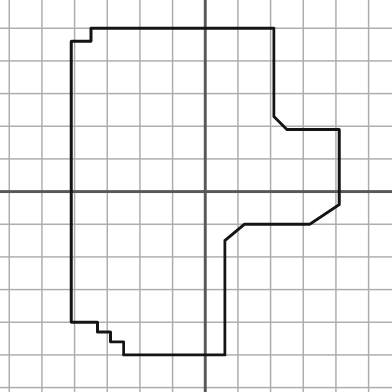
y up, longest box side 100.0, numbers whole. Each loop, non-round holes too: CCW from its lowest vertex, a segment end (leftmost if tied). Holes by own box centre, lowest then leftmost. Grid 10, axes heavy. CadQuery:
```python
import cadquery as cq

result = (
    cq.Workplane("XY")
    .moveTo(-25.0, -50.0)
    .lineTo(6.0, -50.0)
    .lineTo(6.0, -15.0)
    .lineTo(12.0, -10.0)
    .lineTo(32.0, -10.0)
    .lineTo(41.0, -4.0)
    .lineTo(41.0, 19.0)
    .lineTo(25.0, 19.0)
    .lineTo(21.0, 23.0)
    .lineTo(21.0, 50.0)
    .lineTo(-35.0, 50.0)
    .lineTo(-35.0, 46.0)
    .lineTo(-41.0, 46.0)
    .lineTo(-41.0, -40.0)
    .lineTo(-33.0, -40.0)
    .lineTo(-33.0, -43.0)
    .lineTo(-29.0, -43.0)
    .lineTo(-29.0, -46.0)
    .lineTo(-25.0, -46.0)
    .close()
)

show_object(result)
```